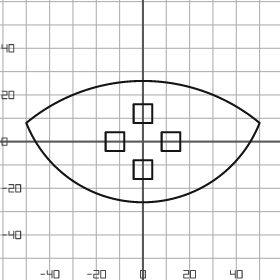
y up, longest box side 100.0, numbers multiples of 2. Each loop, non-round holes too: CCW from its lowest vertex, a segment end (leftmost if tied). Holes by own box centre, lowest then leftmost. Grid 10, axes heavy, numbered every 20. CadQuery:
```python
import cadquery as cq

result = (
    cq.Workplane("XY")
    .moveTo(-50.0, 8.0)
    .threePointArc((0.0, -26.0), (50.0, 8.0))
    .threePointArc((0.0, 26.0), (-50.0, 8.0))
    .close()
    .moveTo(-4.0, -16.0)
    .lineTo(4.0, -16.0)
    .lineTo(4.0, -8.0)
    .lineTo(-4.0, -8.0)
    .close()
    .moveTo(-16.0, -4.0)
    .lineTo(-8.0, -4.0)
    .lineTo(-8.0, 4.0)
    .lineTo(-16.0, 4.0)
    .close()
    .moveTo(8.0, -4.0)
    .lineTo(16.0, -4.0)
    .lineTo(16.0, 4.0)
    .lineTo(8.0, 4.0)
    .close()
    .moveTo(-4.0, 8.0)
    .lineTo(4.0, 8.0)
    .lineTo(4.0, 16.0)
    .lineTo(-4.0, 16.0)
    .close()
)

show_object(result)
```